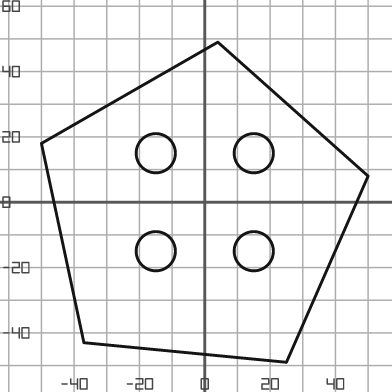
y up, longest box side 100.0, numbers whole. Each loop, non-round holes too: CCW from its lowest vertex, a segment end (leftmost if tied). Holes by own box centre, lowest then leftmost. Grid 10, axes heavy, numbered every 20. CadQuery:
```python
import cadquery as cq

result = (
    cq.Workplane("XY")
    .moveTo(25.0, -49.0)
    .lineTo(50.0, 8.0)
    .lineTo(4.0, 49.0)
    .lineTo(-50.0, 18.0)
    .lineTo(-37.0, -43.0)
    .close()
    .moveTo(-15.0, -15.0)
    .circle(6.0)
    .moveTo(15.0, -15.0)
    .circle(6.0)
    .moveTo(-15.0, 15.0)
    .circle(6.0)
    .moveTo(15.0, 15.0)
    .circle(6.0)
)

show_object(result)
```